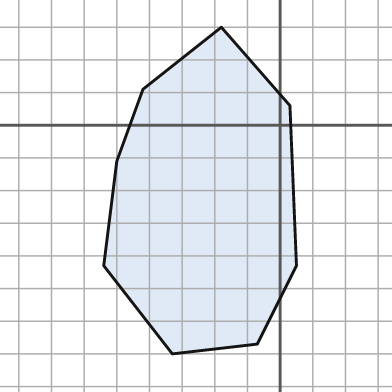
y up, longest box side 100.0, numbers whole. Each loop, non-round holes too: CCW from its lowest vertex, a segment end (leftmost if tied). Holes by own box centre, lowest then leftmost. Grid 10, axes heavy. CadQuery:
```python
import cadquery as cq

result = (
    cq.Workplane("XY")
    .moveTo(-33.0, -70.0)
    .lineTo(-7.0, -67.0)
    .lineTo(5.0, -43.0)
    .lineTo(3.0, 6.0)
    .lineTo(-18.0, 30.0)
    .lineTo(-42.0, 11.0)
    .lineTo(-50.0, -11.0)
    .lineTo(-54.0, -43.0)
    .close()
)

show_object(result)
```